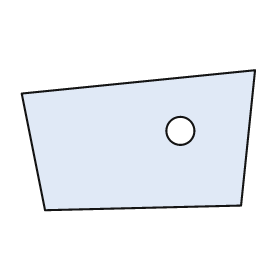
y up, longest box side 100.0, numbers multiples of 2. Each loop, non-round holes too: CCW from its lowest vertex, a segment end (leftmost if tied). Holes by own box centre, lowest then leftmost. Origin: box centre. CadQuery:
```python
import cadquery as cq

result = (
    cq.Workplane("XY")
    .moveTo(-40.0, -30.0)
    .lineTo(44.0, -28.0)
    .lineTo(50.0, 30.0)
    .lineTo(-50.0, 20.0)
    .close()
    .moveTo(18.0, 4.0)
    .circle(6.0)
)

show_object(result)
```